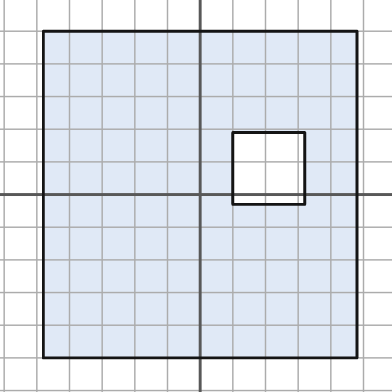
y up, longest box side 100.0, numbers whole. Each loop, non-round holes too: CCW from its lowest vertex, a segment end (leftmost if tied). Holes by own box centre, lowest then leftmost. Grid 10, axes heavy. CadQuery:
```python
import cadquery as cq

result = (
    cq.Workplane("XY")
    .moveTo(-48.0, -50.0)
    .lineTo(48.0, -50.0)
    .lineTo(48.0, 50.0)
    .lineTo(-48.0, 50.0)
    .close()
    .moveTo(10.0, -3.0)
    .lineTo(32.0, -3.0)
    .lineTo(32.0, 19.0)
    .lineTo(10.0, 19.0)
    .close()
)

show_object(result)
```